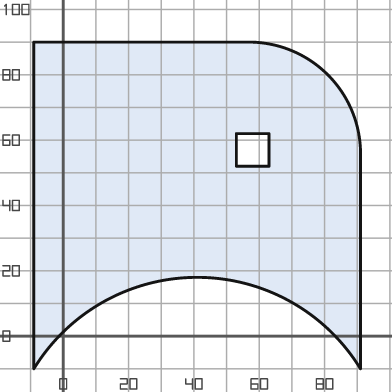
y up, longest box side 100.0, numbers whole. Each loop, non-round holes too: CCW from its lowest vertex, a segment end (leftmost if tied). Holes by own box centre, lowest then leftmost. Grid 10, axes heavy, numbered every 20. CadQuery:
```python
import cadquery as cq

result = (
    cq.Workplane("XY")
    .moveTo(-9.0, -10.0)
    .threePointArc((41.0, 18.0), (91.0, -10.0))
    .lineTo(91.0, 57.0)
    .threePointArc((81.0, 80.0), (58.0, 90.0))
    .lineTo(-9.0, 90.0)
    .close()
    .moveTo(53.0, 52.0)
    .lineTo(63.0, 52.0)
    .lineTo(63.0, 62.0)
    .lineTo(53.0, 62.0)
    .close()
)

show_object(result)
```